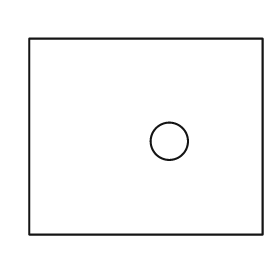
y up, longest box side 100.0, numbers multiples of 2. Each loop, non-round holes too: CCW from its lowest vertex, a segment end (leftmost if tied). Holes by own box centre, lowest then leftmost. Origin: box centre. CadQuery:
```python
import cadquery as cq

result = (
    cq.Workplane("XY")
    .moveTo(-50.0, -42.0)
    .lineTo(50.0, -42.0)
    .lineTo(50.0, 42.0)
    .lineTo(-50.0, 42.0)
    .close()
    .moveTo(10.0, -2.0)
    .circle(8.0)
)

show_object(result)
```